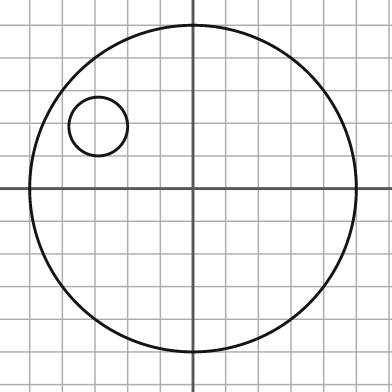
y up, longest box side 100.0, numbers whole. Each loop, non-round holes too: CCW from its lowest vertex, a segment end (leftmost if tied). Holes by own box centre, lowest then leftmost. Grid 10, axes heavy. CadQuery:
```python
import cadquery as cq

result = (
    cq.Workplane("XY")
    .moveTo(0.0, 0.0)
    .circle(50.0)
    .moveTo(-29.0, 19.0)
    .circle(9.0)
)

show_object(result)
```